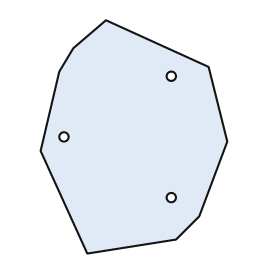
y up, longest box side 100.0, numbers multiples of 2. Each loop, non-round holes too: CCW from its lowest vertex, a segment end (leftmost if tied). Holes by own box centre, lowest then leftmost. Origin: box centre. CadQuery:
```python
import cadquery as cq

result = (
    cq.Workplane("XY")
    .moveTo(-20.0, -50.0)
    .lineTo(18.0, -44.0)
    .lineTo(28.0, -34.0)
    .lineTo(40.0, -2.0)
    .lineTo(32.0, 30.0)
    .lineTo(-12.0, 50.0)
    .lineTo(-26.0, 38.0)
    .lineTo(-32.0, 28.0)
    .lineTo(-40.0, -6.0)
    .close()
    .moveTo(16.0, -26.0)
    .circle(2.0)
    .moveTo(-30.0, 0.0)
    .circle(2.0)
    .moveTo(16.0, 26.0)
    .circle(2.0)
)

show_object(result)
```